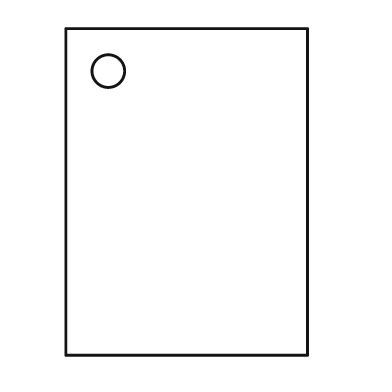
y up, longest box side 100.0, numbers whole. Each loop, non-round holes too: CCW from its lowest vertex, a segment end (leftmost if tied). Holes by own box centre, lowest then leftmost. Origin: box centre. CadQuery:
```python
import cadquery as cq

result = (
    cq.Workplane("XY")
    .moveTo(-37.0, -50.0)
    .lineTo(37.0, -50.0)
    .lineTo(37.0, 50.0)
    .lineTo(-37.0, 50.0)
    .close()
    .moveTo(-24.0, 37.0)
    .circle(5.0)
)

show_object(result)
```